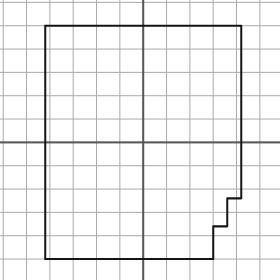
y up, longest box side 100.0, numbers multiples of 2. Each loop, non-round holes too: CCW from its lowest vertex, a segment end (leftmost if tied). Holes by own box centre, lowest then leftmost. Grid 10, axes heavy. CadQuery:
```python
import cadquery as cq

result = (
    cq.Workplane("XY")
    .moveTo(-42.0, -50.0)
    .lineTo(30.0, -50.0)
    .lineTo(30.0, -36.0)
    .lineTo(36.0, -36.0)
    .lineTo(36.0, -24.0)
    .lineTo(42.0, -24.0)
    .lineTo(42.0, 50.0)
    .lineTo(-42.0, 50.0)
    .close()
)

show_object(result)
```